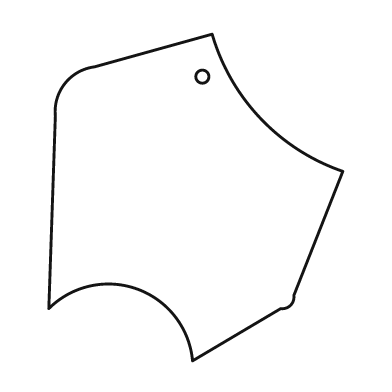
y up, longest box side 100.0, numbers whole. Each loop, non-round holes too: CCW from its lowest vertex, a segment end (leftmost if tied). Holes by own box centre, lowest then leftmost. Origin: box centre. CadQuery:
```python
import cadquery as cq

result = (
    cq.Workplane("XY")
    .moveTo(-1.0, -50.0)
    .lineTo(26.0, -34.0)
    .threePointArc((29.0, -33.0), (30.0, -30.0))
    .lineTo(45.0, 8.0)
    .threePointArc((20.0, 24.0), (5.0, 50.0))
    .lineTo(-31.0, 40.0)
    .threePointArc((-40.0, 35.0), (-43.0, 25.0))
    .lineTo(-45.0, -34.0)
    .threePointArc((-18.0, -28.0), (-1.0, -50.0))
    .close()
    .moveTo(2.0, 37.0)
    .circle(2.0)
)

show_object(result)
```